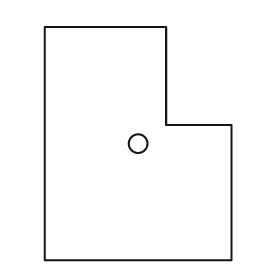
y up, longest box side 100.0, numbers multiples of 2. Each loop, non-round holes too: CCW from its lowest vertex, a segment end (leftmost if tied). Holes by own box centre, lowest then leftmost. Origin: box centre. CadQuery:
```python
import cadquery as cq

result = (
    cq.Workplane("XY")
    .moveTo(-40.0, -50.0)
    .lineTo(40.0, -50.0)
    .lineTo(40.0, 8.0)
    .lineTo(12.0, 8.0)
    .lineTo(12.0, 50.0)
    .lineTo(-40.0, 50.0)
    .close()
    .moveTo(0.0, 0.0)
    .circle(4.0)
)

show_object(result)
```